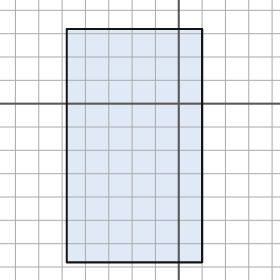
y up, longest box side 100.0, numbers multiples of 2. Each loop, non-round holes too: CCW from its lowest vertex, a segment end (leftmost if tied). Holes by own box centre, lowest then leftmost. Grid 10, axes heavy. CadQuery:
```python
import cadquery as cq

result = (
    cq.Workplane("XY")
    .moveTo(-48.0, -68.0)
    .lineTo(10.0, -68.0)
    .lineTo(10.0, 32.0)
    .lineTo(-48.0, 32.0)
    .close()
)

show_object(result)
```